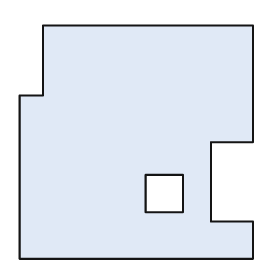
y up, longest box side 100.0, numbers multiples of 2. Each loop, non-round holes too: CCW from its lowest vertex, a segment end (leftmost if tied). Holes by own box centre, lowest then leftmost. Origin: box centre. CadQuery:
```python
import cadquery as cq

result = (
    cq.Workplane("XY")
    .moveTo(-50.0, -50.0)
    .lineTo(50.0, -50.0)
    .lineTo(50.0, -34.0)
    .lineTo(32.0, -34.0)
    .lineTo(32.0, 0.0)
    .lineTo(50.0, 0.0)
    .lineTo(50.0, 50.0)
    .lineTo(-40.0, 50.0)
    .lineTo(-40.0, 20.0)
    .lineTo(-50.0, 20.0)
    .close()
    .moveTo(4.0, -30.0)
    .lineTo(20.0, -30.0)
    .lineTo(20.0, -14.0)
    .lineTo(4.0, -14.0)
    .close()
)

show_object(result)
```